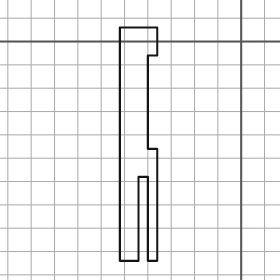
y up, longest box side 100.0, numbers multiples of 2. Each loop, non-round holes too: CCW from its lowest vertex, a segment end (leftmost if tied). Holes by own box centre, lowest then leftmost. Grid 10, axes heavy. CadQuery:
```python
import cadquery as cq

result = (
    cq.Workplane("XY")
    .moveTo(-52.0, -94.0)
    .lineTo(-44.0, -94.0)
    .lineTo(-44.0, -58.0)
    .lineTo(-40.0, -58.0)
    .lineTo(-40.0, -94.0)
    .lineTo(-36.0, -94.0)
    .lineTo(-36.0, -46.0)
    .lineTo(-40.0, -46.0)
    .lineTo(-40.0, -6.0)
    .lineTo(-36.0, -6.0)
    .lineTo(-36.0, 6.0)
    .lineTo(-52.0, 6.0)
    .close()
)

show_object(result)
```